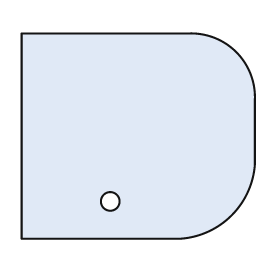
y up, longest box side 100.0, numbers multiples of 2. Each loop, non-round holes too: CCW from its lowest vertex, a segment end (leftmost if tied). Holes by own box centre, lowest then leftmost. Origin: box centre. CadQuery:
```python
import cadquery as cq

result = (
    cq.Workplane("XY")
    .moveTo(-50.0, -44.0)
    .lineTo(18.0, -44.0)
    .threePointArc((40.0, -34.0), (50.0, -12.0))
    .lineTo(50.0, 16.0)
    .threePointArc((42.0, 36.0), (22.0, 44.0))
    .lineTo(-50.0, 44.0)
    .close()
    .moveTo(-12.0, -28.0)
    .circle(4.0)
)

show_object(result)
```